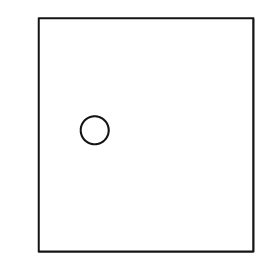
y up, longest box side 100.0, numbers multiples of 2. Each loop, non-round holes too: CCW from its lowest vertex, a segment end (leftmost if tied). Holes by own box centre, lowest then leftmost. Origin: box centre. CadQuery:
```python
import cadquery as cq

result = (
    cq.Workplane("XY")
    .moveTo(-46.0, -50.0)
    .lineTo(46.0, -50.0)
    .lineTo(46.0, 50.0)
    .lineTo(-46.0, 50.0)
    .close()
    .moveTo(-22.0, 2.0)
    .circle(6.0)
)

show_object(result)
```